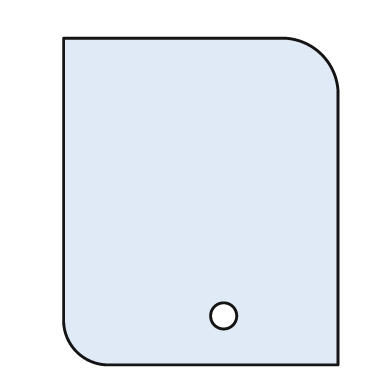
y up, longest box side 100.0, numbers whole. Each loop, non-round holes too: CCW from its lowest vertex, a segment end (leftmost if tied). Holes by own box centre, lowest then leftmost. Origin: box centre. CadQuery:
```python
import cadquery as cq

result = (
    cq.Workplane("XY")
    .moveTo(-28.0, -50.0)
    .lineTo(42.0, -50.0)
    .lineTo(42.0, 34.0)
    .threePointArc((37.0, 45.0), (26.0, 50.0))
    .lineTo(-42.0, 50.0)
    .lineTo(-42.0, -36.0)
    .threePointArc((-38.0, -46.0), (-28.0, -50.0))
    .close()
    .moveTo(7.0, -35.0)
    .circle(4.0)
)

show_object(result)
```